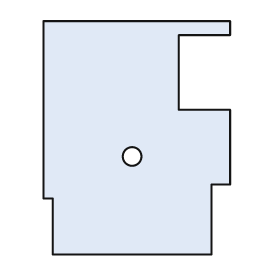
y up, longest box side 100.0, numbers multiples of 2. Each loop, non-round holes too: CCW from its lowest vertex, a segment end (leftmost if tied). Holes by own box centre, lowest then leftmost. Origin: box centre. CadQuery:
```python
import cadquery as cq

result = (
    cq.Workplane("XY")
    .moveTo(-36.0, -50.0)
    .lineTo(32.0, -50.0)
    .lineTo(32.0, -20.0)
    .lineTo(40.0, -20.0)
    .lineTo(40.0, 12.0)
    .lineTo(18.0, 12.0)
    .lineTo(18.0, 44.0)
    .lineTo(40.0, 44.0)
    .lineTo(40.0, 50.0)
    .lineTo(-40.0, 50.0)
    .lineTo(-40.0, -26.0)
    .lineTo(-36.0, -26.0)
    .close()
    .moveTo(-2.0, -8.0)
    .circle(4.0)
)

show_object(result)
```